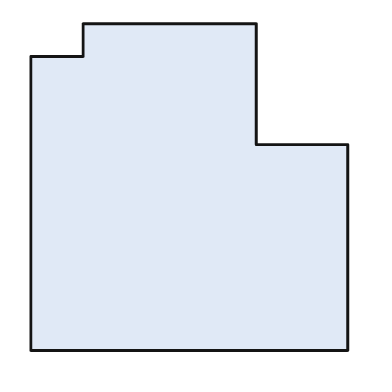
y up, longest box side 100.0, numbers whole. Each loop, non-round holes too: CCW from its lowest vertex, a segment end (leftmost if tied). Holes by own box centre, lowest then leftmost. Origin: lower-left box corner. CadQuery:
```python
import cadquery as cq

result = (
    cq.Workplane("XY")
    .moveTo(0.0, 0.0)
    .lineTo(97.0, 0.0)
    .lineTo(97.0, 63.0)
    .lineTo(69.0, 63.0)
    .lineTo(69.0, 100.0)
    .lineTo(16.0, 100.0)
    .lineTo(16.0, 90.0)
    .lineTo(0.0, 90.0)
    .close()
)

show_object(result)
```